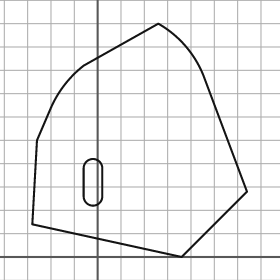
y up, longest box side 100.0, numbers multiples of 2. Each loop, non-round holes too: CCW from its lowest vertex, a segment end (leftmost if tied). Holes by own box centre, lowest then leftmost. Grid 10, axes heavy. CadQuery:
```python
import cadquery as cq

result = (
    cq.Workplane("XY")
    .moveTo(36.0, 0.0)
    .lineTo(64.0, 28.0)
    .lineTo(46.0, 76.0)
    .threePointArc((38.0, 90.0), (26.0, 100.0))
    .lineTo(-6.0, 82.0)
    .threePointArc((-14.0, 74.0), (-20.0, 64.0))
    .lineTo(-26.0, 50.0)
    .lineTo(-28.0, 14.0)
    .close()
    .moveTo(-6.0, 26.0)
    .threePointArc((-2.0, 22.0), (2.0, 26.0))
    .lineTo(2.0, 38.0)
    .threePointArc((-2.0, 42.0), (-6.0, 38.0))
    .close()
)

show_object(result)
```